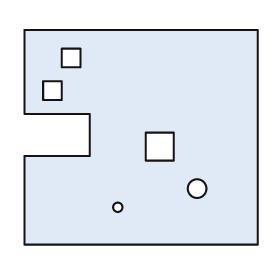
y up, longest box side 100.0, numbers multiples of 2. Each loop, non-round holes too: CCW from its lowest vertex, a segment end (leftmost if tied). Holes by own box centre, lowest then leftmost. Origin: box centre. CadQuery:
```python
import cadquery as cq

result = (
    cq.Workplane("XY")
    .moveTo(-50.0, -46.0)
    .lineTo(50.0, -46.0)
    .lineTo(50.0, 46.0)
    .lineTo(-50.0, 46.0)
    .lineTo(-50.0, 10.0)
    .lineTo(-22.0, 10.0)
    .lineTo(-22.0, -8.0)
    .lineTo(-50.0, -8.0)
    .close()
    .moveTo(-10.0, -30.0)
    .circle(2.0)
    .moveTo(24.0, -22.0)
    .circle(4.0)
    .moveTo(2.0, -10.0)
    .lineTo(14.0, -10.0)
    .lineTo(14.0, 2.0)
    .lineTo(2.0, 2.0)
    .close()
    .moveTo(-42.0, 16.0)
    .lineTo(-34.0, 16.0)
    .lineTo(-34.0, 24.0)
    .lineTo(-42.0, 24.0)
    .close()
    .moveTo(-34.0, 30.0)
    .lineTo(-26.0, 30.0)
    .lineTo(-26.0, 38.0)
    .lineTo(-34.0, 38.0)
    .close()
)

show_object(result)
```